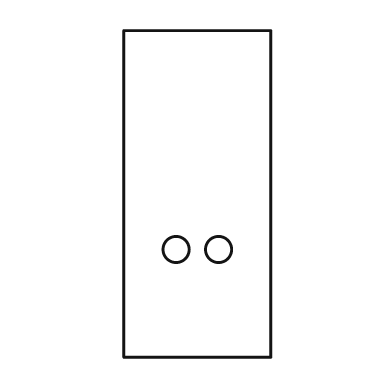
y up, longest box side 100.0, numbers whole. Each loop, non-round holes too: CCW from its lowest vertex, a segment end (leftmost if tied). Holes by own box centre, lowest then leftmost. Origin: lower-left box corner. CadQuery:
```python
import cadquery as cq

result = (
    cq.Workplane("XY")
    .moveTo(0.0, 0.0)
    .lineTo(45.0, 0.0)
    .lineTo(45.0, 100.0)
    .lineTo(0.0, 100.0)
    .close()
    .moveTo(16.0, 33.0)
    .circle(4.0)
    .moveTo(29.0, 33.0)
    .circle(4.0)
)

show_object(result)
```